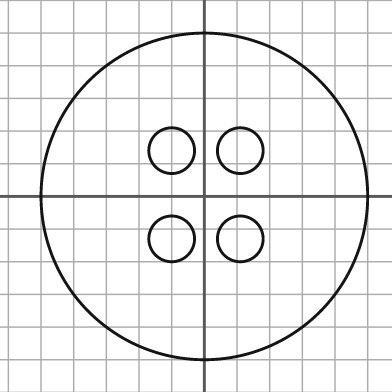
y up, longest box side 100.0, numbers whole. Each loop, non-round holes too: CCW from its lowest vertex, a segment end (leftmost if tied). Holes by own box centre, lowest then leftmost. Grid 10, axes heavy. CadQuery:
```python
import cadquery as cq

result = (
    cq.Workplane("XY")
    .moveTo(0.0, 0.0)
    .circle(50.0)
    .moveTo(-10.0, -13.0)
    .circle(7.0)
    .moveTo(11.0, -13.0)
    .circle(7.0)
    .moveTo(-10.0, 14.0)
    .circle(7.0)
    .moveTo(11.0, 14.0)
    .circle(7.0)
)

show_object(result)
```